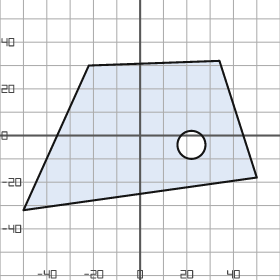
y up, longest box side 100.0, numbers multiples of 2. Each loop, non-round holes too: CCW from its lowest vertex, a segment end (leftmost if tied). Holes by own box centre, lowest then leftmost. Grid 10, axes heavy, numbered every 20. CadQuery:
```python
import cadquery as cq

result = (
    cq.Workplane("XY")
    .moveTo(-50.0, -32.0)
    .lineTo(50.0, -18.0)
    .lineTo(34.0, 32.0)
    .lineTo(-22.0, 30.0)
    .close()
    .moveTo(22.0, -4.0)
    .circle(6.0)
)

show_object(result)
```